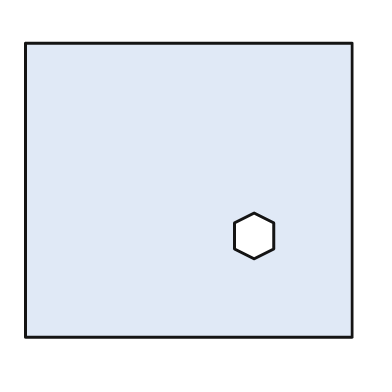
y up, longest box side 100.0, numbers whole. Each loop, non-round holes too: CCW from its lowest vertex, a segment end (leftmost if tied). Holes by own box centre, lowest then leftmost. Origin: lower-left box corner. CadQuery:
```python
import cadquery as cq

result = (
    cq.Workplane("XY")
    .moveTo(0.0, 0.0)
    .lineTo(100.0, 0.0)
    .lineTo(100.0, 90.0)
    .lineTo(0.0, 90.0)
    .close()
    .moveTo(70.0, 24.0)
    .lineTo(76.0, 27.0)
    .lineTo(76.0, 35.0)
    .lineTo(70.0, 38.0)
    .lineTo(64.0, 35.0)
    .lineTo(64.0, 27.0)
    .close()
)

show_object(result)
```